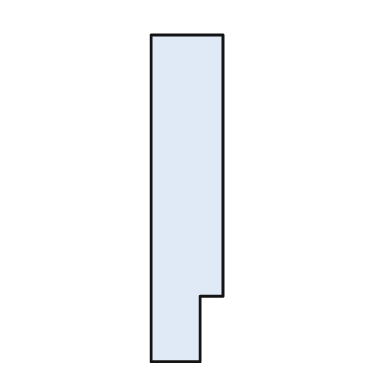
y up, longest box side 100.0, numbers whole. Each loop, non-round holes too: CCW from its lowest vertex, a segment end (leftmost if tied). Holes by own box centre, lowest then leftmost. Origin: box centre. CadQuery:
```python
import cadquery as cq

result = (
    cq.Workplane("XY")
    .moveTo(-11.0, -50.0)
    .lineTo(4.0, -50.0)
    .lineTo(4.0, -30.0)
    .lineTo(11.0, -30.0)
    .lineTo(11.0, 50.0)
    .lineTo(-11.0, 50.0)
    .close()
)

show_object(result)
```